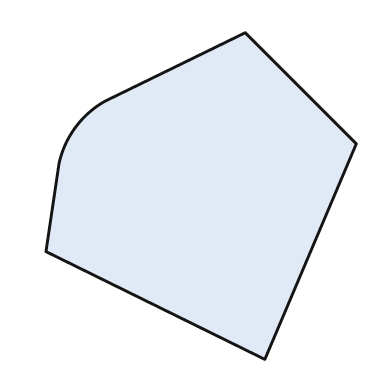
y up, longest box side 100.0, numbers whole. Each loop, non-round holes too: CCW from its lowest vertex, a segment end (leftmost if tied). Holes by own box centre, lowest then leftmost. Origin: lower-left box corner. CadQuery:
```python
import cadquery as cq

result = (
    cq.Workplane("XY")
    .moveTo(67.0, 0.0)
    .lineTo(95.0, 66.0)
    .lineTo(61.0, 100.0)
    .lineTo(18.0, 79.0)
    .threePointArc((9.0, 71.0), (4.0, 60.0))
    .lineTo(0.0, 33.0)
    .close()
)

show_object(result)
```